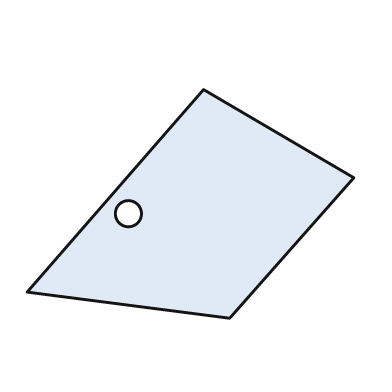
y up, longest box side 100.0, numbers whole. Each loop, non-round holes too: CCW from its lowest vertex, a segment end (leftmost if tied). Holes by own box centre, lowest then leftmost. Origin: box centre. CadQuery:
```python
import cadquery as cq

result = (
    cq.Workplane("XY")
    .moveTo(12.0, -35.0)
    .lineTo(50.0, 8.0)
    .lineTo(4.0, 35.0)
    .lineTo(-50.0, -27.0)
    .close()
    .moveTo(-19.0, -3.0)
    .circle(4.0)
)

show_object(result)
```